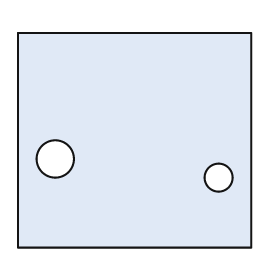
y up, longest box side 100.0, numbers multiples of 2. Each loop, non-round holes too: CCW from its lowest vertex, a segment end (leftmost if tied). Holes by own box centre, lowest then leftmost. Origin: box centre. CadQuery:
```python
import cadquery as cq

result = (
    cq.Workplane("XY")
    .moveTo(-50.0, -46.0)
    .lineTo(50.0, -46.0)
    .lineTo(50.0, 46.0)
    .lineTo(-50.0, 46.0)
    .close()
    .moveTo(36.0, -16.0)
    .circle(6.0)
    .moveTo(-34.0, -8.0)
    .circle(8.0)
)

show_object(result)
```